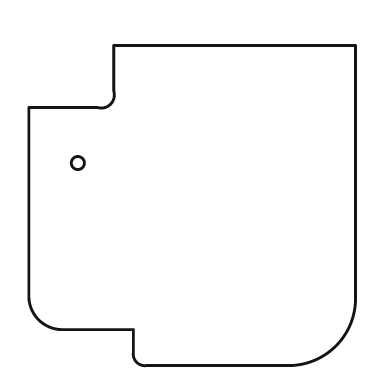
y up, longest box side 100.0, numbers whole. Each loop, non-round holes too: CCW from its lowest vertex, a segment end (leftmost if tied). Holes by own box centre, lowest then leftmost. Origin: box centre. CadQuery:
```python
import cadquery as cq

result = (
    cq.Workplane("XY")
    .moveTo(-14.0, -49.0)
    .lineTo(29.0, -49.0)
    .threePointArc((44.0, -43.0), (50.0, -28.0))
    .lineTo(50.0, 49.0)
    .lineTo(-24.0, 49.0)
    .lineTo(-24.0, 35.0)
    .threePointArc((-25.0, 31.0), (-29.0, 30.0))
    .lineTo(-50.0, 30.0)
    .lineTo(-50.0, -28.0)
    .threePointArc((-47.0, -35.0), (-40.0, -38.0))
    .lineTo(-18.0, -38.0)
    .lineTo(-18.0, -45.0)
    .threePointArc((-17.0, -48.0), (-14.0, -49.0))
    .close()
    .moveTo(-35.0, 13.0)
    .circle(2.0)
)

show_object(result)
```